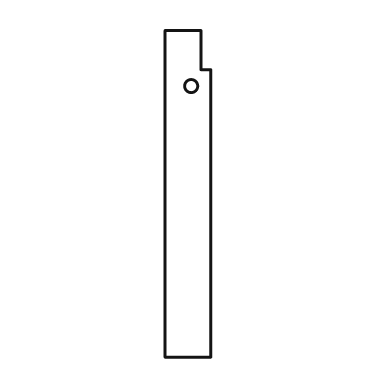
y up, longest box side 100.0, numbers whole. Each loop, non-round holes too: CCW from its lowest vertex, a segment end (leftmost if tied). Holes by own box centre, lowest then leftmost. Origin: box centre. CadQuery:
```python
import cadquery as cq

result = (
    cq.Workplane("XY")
    .moveTo(-7.0, -50.0)
    .lineTo(7.0, -50.0)
    .lineTo(7.0, 38.0)
    .lineTo(4.0, 38.0)
    .lineTo(4.0, 50.0)
    .lineTo(-7.0, 50.0)
    .close()
    .moveTo(1.0, 33.0)
    .circle(2.0)
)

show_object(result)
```